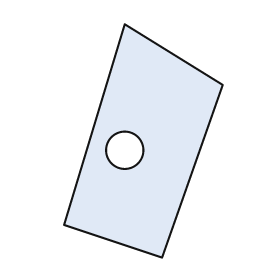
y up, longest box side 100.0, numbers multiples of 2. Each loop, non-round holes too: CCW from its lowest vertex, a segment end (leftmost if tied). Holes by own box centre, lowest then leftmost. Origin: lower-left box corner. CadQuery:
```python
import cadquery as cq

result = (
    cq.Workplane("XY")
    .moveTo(42.0, 0.0)
    .lineTo(68.0, 74.0)
    .lineTo(26.0, 100.0)
    .lineTo(0.0, 14.0)
    .close()
    .moveTo(26.0, 46.0)
    .circle(8.0)
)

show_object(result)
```